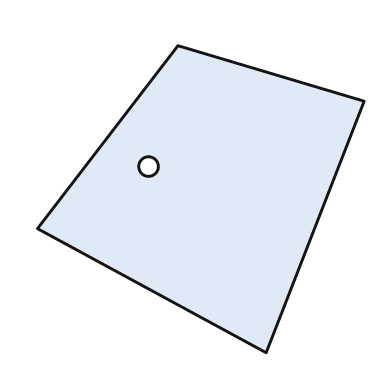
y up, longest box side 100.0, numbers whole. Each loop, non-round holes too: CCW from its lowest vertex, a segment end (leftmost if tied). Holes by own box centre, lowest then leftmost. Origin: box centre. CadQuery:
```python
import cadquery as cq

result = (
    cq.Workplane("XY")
    .moveTo(20.0, -47.0)
    .lineTo(50.0, 30.0)
    .lineTo(-7.0, 47.0)
    .lineTo(-50.0, -9.0)
    .close()
    .moveTo(-16.0, 10.0)
    .circle(3.0)
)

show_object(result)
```